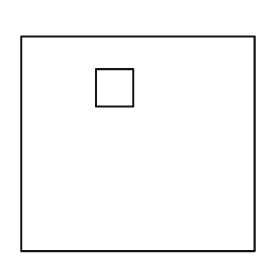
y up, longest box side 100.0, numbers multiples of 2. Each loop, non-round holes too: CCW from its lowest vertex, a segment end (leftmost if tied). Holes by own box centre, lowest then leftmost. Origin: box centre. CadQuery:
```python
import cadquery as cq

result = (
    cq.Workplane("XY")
    .moveTo(-50.0, -46.0)
    .lineTo(50.0, -46.0)
    .lineTo(50.0, 46.0)
    .lineTo(-50.0, 46.0)
    .close()
    .moveTo(-18.0, 16.0)
    .lineTo(-2.0, 16.0)
    .lineTo(-2.0, 32.0)
    .lineTo(-18.0, 32.0)
    .close()
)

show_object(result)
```